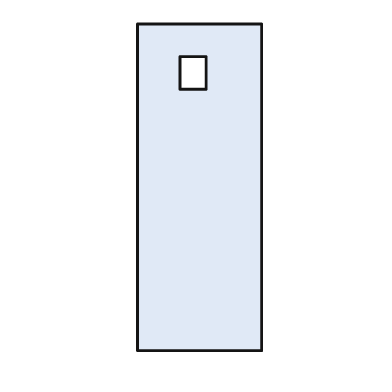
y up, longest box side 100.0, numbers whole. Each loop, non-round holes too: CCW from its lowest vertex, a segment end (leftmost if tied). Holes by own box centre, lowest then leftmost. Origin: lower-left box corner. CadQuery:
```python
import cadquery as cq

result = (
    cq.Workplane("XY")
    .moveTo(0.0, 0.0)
    .lineTo(38.0, 0.0)
    .lineTo(38.0, 100.0)
    .lineTo(0.0, 100.0)
    .close()
    .moveTo(13.0, 80.0)
    .lineTo(21.0, 80.0)
    .lineTo(21.0, 90.0)
    .lineTo(13.0, 90.0)
    .close()
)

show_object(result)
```